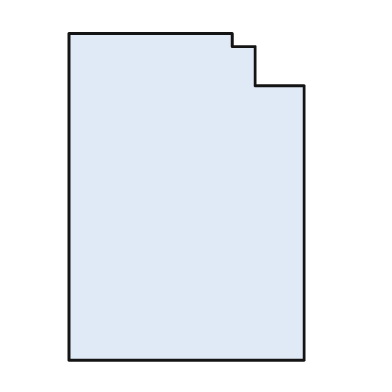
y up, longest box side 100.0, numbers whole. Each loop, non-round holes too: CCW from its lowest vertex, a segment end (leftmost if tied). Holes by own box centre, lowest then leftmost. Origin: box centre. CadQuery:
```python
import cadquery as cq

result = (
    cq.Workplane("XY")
    .moveTo(-36.0, -50.0)
    .lineTo(36.0, -50.0)
    .lineTo(36.0, 34.0)
    .lineTo(21.0, 34.0)
    .lineTo(21.0, 46.0)
    .lineTo(14.0, 46.0)
    .lineTo(14.0, 50.0)
    .lineTo(-36.0, 50.0)
    .close()
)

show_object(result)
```